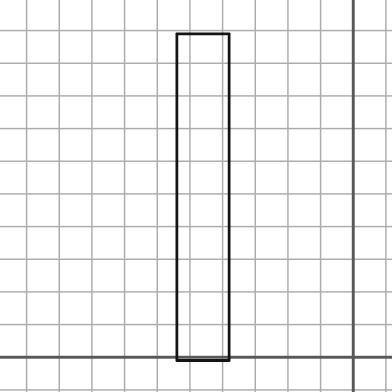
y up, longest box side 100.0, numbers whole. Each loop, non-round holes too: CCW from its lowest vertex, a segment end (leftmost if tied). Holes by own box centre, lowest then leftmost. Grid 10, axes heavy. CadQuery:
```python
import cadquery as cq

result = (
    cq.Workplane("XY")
    .moveTo(-54.0, -1.0)
    .lineTo(-38.0, -1.0)
    .lineTo(-38.0, 99.0)
    .lineTo(-54.0, 99.0)
    .close()
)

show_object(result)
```